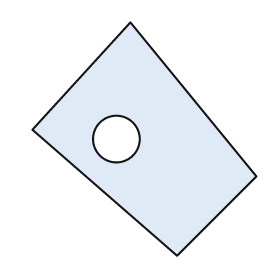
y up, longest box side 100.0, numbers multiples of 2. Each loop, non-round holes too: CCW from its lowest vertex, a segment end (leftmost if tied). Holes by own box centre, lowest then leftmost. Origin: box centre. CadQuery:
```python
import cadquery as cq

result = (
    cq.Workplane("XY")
    .moveTo(14.0, -50.0)
    .lineTo(48.0, -16.0)
    .lineTo(-6.0, 50.0)
    .lineTo(-48.0, 4.0)
    .close()
    .moveTo(-12.0, 0.0)
    .circle(10.0)
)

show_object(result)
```